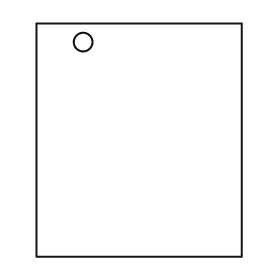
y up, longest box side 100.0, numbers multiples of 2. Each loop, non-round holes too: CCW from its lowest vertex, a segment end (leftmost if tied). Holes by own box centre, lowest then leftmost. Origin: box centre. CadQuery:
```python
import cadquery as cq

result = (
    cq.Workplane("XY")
    .moveTo(-44.0, -50.0)
    .lineTo(44.0, -50.0)
    .lineTo(44.0, 50.0)
    .lineTo(-44.0, 50.0)
    .close()
    .moveTo(-24.0, 42.0)
    .circle(4.0)
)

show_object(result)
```